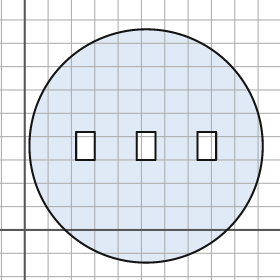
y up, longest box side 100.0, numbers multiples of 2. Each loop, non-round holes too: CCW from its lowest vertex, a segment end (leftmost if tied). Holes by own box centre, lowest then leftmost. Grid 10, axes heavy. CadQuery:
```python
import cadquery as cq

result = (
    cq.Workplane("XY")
    .moveTo(52.0, 36.0)
    .circle(50.0)
    .moveTo(22.0, 30.0)
    .lineTo(30.0, 30.0)
    .lineTo(30.0, 42.0)
    .lineTo(22.0, 42.0)
    .close()
    .moveTo(48.0, 30.0)
    .lineTo(56.0, 30.0)
    .lineTo(56.0, 42.0)
    .lineTo(48.0, 42.0)
    .close()
    .moveTo(74.0, 30.0)
    .lineTo(82.0, 30.0)
    .lineTo(82.0, 42.0)
    .lineTo(74.0, 42.0)
    .close()
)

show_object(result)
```